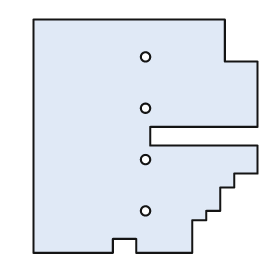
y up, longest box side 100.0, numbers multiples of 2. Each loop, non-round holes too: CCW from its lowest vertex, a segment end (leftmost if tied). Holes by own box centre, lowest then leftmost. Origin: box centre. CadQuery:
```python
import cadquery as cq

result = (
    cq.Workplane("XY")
    .moveTo(-48.0, -50.0)
    .lineTo(-14.0, -50.0)
    .lineTo(-14.0, -44.0)
    .lineTo(-4.0, -44.0)
    .lineTo(-4.0, -50.0)
    .lineTo(20.0, -50.0)
    .lineTo(20.0, -36.0)
    .lineTo(26.0, -36.0)
    .lineTo(26.0, -32.0)
    .lineTo(32.0, -32.0)
    .lineTo(32.0, -22.0)
    .lineTo(38.0, -22.0)
    .lineTo(38.0, -16.0)
    .lineTo(48.0, -16.0)
    .lineTo(48.0, -4.0)
    .lineTo(2.0, -4.0)
    .lineTo(2.0, 4.0)
    .lineTo(48.0, 4.0)
    .lineTo(48.0, 32.0)
    .lineTo(34.0, 32.0)
    .lineTo(34.0, 50.0)
    .lineTo(-48.0, 50.0)
    .close()
    .moveTo(0.0, -32.0)
    .circle(2.0)
    .moveTo(0.0, -10.0)
    .circle(2.0)
    .moveTo(0.0, 12.0)
    .circle(2.0)
    .moveTo(0.0, 34.0)
    .circle(2.0)
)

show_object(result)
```